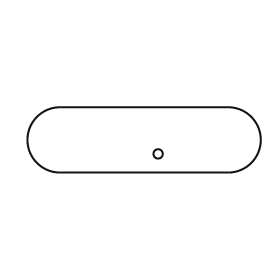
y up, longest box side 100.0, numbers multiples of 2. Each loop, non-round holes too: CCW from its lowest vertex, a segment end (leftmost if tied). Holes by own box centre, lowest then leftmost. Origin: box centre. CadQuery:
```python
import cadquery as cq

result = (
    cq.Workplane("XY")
    .moveTo(-36.0, -14.0)
    .lineTo(36.0, -14.0)
    .threePointArc((50.0, 0.0), (36.0, 14.0))
    .lineTo(-36.0, 14.0)
    .threePointArc((-50.0, 0.0), (-36.0, -14.0))
    .close()
    .moveTo(6.0, -6.0)
    .circle(2.0)
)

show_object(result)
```